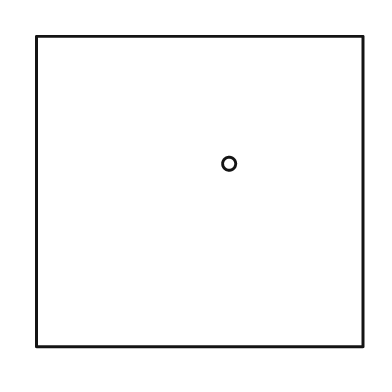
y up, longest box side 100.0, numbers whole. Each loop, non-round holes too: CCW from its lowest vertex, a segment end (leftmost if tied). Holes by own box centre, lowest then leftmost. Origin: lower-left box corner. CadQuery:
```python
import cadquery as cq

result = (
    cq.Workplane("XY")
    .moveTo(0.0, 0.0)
    .lineTo(100.0, 0.0)
    .lineTo(100.0, 95.0)
    .lineTo(0.0, 95.0)
    .close()
    .moveTo(59.0, 56.0)
    .circle(2.0)
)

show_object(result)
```